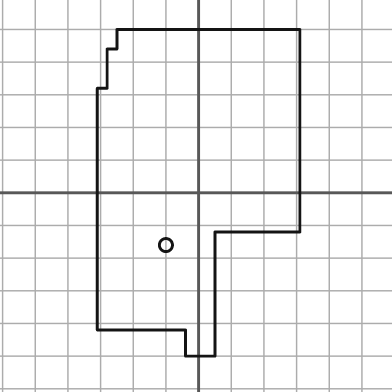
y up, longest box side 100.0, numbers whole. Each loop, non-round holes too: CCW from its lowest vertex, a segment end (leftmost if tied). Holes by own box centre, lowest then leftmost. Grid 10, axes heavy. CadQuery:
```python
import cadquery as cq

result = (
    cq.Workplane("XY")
    .moveTo(-4.0, -50.0)
    .lineTo(5.0, -50.0)
    .lineTo(5.0, -12.0)
    .lineTo(31.0, -12.0)
    .lineTo(31.0, 50.0)
    .lineTo(-25.0, 50.0)
    .lineTo(-25.0, 44.0)
    .lineTo(-28.0, 44.0)
    .lineTo(-28.0, 32.0)
    .lineTo(-31.0, 32.0)
    .lineTo(-31.0, -42.0)
    .lineTo(-4.0, -42.0)
    .close()
    .moveTo(-10.0, -16.0)
    .circle(2.0)
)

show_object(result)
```